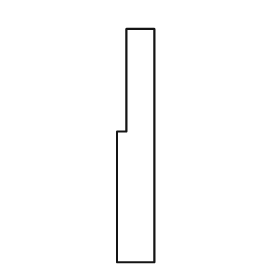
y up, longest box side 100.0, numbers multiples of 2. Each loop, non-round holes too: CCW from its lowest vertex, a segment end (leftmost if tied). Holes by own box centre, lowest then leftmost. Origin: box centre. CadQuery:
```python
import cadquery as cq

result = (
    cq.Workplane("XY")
    .moveTo(-8.0, -50.0)
    .lineTo(8.0, -50.0)
    .lineTo(8.0, 50.0)
    .lineTo(-4.0, 50.0)
    .lineTo(-4.0, 6.0)
    .lineTo(-8.0, 6.0)
    .close()
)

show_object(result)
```